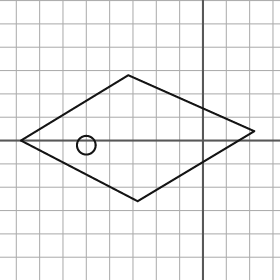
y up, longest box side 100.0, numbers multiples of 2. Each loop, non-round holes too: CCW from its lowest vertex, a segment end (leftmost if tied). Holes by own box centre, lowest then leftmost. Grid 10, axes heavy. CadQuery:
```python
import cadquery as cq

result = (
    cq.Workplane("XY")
    .moveTo(-28.0, -26.0)
    .lineTo(22.0, 4.0)
    .lineTo(-32.0, 28.0)
    .lineTo(-78.0, 0.0)
    .close()
    .moveTo(-50.0, -2.0)
    .circle(4.0)
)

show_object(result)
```